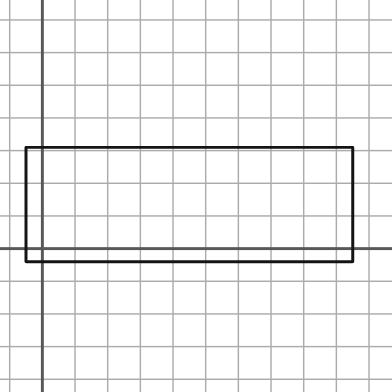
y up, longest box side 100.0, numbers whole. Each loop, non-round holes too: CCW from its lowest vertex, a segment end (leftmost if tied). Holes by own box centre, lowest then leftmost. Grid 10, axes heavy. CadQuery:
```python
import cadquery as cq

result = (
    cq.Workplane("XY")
    .moveTo(-5.0, -4.0)
    .lineTo(95.0, -4.0)
    .lineTo(95.0, 31.0)
    .lineTo(-5.0, 31.0)
    .close()
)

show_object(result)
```